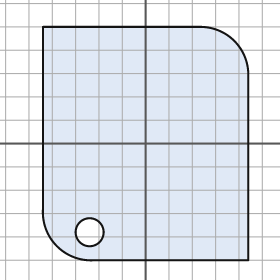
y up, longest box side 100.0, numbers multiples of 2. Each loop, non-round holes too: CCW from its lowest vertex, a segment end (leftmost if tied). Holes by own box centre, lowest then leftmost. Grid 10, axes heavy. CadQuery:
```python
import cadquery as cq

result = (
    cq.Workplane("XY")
    .moveTo(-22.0, -50.0)
    .lineTo(44.0, -50.0)
    .lineTo(44.0, 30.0)
    .threePointArc((38.0, 44.0), (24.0, 50.0))
    .lineTo(-44.0, 50.0)
    .lineTo(-44.0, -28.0)
    .threePointArc((-38.0, -44.0), (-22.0, -50.0))
    .close()
    .moveTo(-24.0, -38.0)
    .circle(6.0)
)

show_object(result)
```